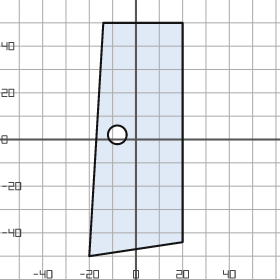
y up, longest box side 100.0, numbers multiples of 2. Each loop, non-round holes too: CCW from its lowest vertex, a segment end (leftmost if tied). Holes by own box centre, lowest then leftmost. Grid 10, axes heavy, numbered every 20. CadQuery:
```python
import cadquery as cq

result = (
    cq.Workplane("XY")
    .moveTo(-20.0, -50.0)
    .lineTo(20.0, -44.0)
    .lineTo(20.0, 50.0)
    .lineTo(-14.0, 50.0)
    .close()
    .moveTo(-8.0, 2.0)
    .circle(4.0)
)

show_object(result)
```